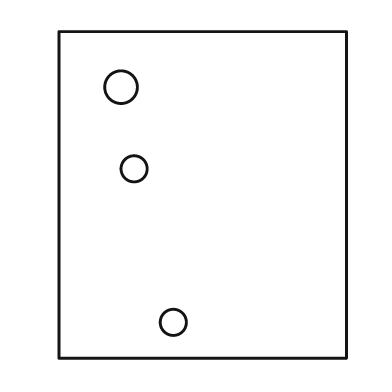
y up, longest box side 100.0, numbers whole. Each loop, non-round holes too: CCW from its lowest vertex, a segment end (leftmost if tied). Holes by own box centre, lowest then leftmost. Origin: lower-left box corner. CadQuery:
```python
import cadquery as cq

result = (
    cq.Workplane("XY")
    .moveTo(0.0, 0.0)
    .lineTo(88.0, 0.0)
    .lineTo(88.0, 100.0)
    .lineTo(0.0, 100.0)
    .close()
    .moveTo(35.0, 11.0)
    .circle(4.0)
    .moveTo(23.0, 58.0)
    .circle(4.0)
    .moveTo(19.0, 83.0)
    .circle(5.0)
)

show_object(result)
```